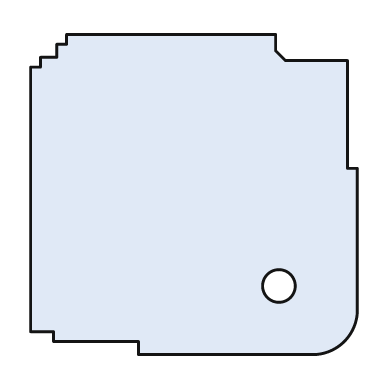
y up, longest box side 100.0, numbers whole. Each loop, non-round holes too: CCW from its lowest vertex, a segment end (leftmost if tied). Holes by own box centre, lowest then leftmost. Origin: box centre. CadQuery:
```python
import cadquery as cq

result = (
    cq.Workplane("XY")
    .moveTo(-17.0, -49.0)
    .lineTo(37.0, -49.0)
    .threePointArc((46.0, -45.0), (50.0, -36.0))
    .lineTo(50.0, 8.0)
    .lineTo(47.0, 8.0)
    .lineTo(47.0, 41.0)
    .lineTo(28.0, 41.0)
    .lineTo(25.0, 44.0)
    .lineTo(25.0, 49.0)
    .lineTo(-39.0, 49.0)
    .lineTo(-39.0, 46.0)
    .lineTo(-42.0, 46.0)
    .lineTo(-42.0, 42.0)
    .lineTo(-47.0, 42.0)
    .lineTo(-47.0, 39.0)
    .lineTo(-50.0, 39.0)
    .lineTo(-50.0, -42.0)
    .lineTo(-43.0, -42.0)
    .lineTo(-43.0, -45.0)
    .lineTo(-17.0, -45.0)
    .close()
    .moveTo(26.0, -28.0)
    .circle(5.0)
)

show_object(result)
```